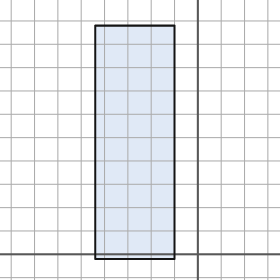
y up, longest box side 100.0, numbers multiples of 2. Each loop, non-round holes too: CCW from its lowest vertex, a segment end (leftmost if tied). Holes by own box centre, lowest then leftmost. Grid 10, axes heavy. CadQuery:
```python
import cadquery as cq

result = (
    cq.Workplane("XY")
    .moveTo(-44.0, -2.0)
    .lineTo(-10.0, -2.0)
    .lineTo(-10.0, 98.0)
    .lineTo(-44.0, 98.0)
    .close()
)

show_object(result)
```